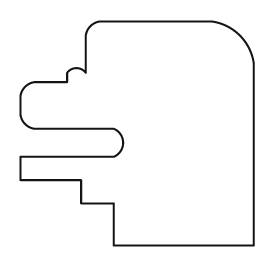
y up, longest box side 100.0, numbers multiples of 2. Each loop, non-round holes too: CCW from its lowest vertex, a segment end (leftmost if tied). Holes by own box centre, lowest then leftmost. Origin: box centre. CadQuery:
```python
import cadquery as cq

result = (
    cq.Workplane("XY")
    .moveTo(-10.0, -48.0)
    .lineTo(50.0, -48.0)
    .lineTo(50.0, 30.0)
    .threePointArc((44.0, 42.0), (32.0, 48.0))
    .lineTo(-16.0, 48.0)
    .threePointArc((-20.0, 46.0), (-22.0, 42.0))
    .lineTo(-22.0, 26.0)
    .threePointArc((-26.0, 28.0), (-30.0, 26.0))
    .lineTo(-30.0, 22.0)
    .lineTo(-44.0, 22.0)
    .threePointArc((-48.0, 20.0), (-50.0, 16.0))
    .lineTo(-50.0, 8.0)
    .threePointArc((-48.0, 4.0), (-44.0, 2.0))
    .lineTo(-10.0, 2.0)
    .threePointArc((-6.0, -4.0), (-10.0, -10.0))
    .lineTo(-50.0, -10.0)
    .lineTo(-50.0, -20.0)
    .lineTo(-24.0, -20.0)
    .lineTo(-24.0, -30.0)
    .lineTo(-10.0, -30.0)
    .close()
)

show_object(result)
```